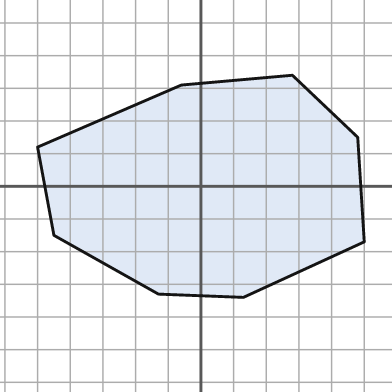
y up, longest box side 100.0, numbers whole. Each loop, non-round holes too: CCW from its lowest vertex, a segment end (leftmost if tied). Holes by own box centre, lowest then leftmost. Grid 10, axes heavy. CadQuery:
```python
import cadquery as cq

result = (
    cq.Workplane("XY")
    .moveTo(13.0, -34.0)
    .lineTo(50.0, -17.0)
    .lineTo(48.0, 15.0)
    .lineTo(28.0, 34.0)
    .lineTo(-6.0, 31.0)
    .lineTo(-50.0, 12.0)
    .lineTo(-45.0, -15.0)
    .lineTo(-13.0, -33.0)
    .close()
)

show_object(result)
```